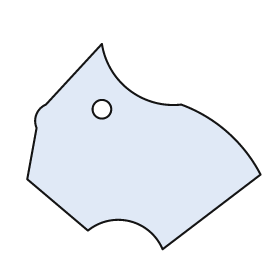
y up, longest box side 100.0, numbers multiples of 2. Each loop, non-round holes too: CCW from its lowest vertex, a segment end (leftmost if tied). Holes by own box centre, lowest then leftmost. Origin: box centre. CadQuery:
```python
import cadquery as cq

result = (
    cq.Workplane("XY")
    .moveTo(8.0, -44.0)
    .lineTo(50.0, -12.0)
    .threePointArc((36.0, 6.0), (16.0, 18.0))
    .threePointArc((-6.0, 24.0), (-18.0, 44.0))
    .lineTo(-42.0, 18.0)
    .threePointArc((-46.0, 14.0), (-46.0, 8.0))
    .lineTo(-50.0, -14.0)
    .lineTo(-24.0, -36.0)
    .threePointArc((-6.0, -32.0), (8.0, -44.0))
    .close()
    .moveTo(-18.0, 16.0)
    .circle(4.0)
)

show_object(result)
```